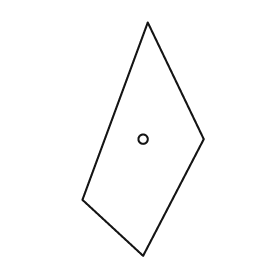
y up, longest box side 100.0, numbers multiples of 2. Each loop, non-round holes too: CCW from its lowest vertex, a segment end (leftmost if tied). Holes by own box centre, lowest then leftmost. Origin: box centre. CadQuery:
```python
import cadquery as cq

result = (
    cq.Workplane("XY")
    .moveTo(0.0, -50.0)
    .lineTo(26.0, 0.0)
    .lineTo(2.0, 50.0)
    .lineTo(-26.0, -26.0)
    .close()
    .moveTo(0.0, 0.0)
    .circle(2.0)
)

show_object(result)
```